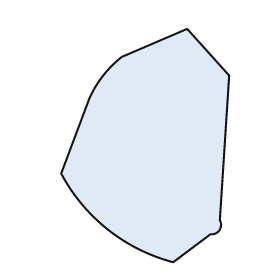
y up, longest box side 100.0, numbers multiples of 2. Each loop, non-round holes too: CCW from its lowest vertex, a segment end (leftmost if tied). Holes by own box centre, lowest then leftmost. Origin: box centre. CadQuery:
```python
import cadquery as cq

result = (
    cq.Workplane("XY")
    .moveTo(12.0, -50.0)
    .lineTo(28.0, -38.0)
    .threePointArc((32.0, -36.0), (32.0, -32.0))
    .lineTo(36.0, 30.0)
    .lineTo(18.0, 50.0)
    .lineTo(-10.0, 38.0)
    .threePointArc((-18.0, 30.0), (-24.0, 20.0))
    .lineTo(-36.0, -12.0)
    .threePointArc((-16.0, -36.0), (12.0, -50.0))
    .close()
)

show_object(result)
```